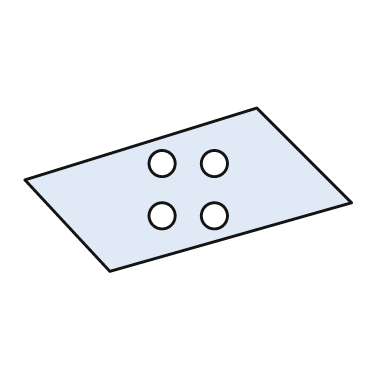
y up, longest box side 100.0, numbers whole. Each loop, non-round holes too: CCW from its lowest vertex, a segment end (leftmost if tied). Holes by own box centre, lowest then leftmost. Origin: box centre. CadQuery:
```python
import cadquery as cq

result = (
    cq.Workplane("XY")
    .moveTo(-24.0, -25.0)
    .lineTo(50.0, -4.0)
    .lineTo(21.0, 25.0)
    .lineTo(-50.0, 3.0)
    .close()
    .moveTo(-8.0, -8.0)
    .circle(4.0)
    .moveTo(8.0, -8.0)
    .circle(4.0)
    .moveTo(-8.0, 8.0)
    .circle(4.0)
    .moveTo(8.0, 8.0)
    .circle(4.0)
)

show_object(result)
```